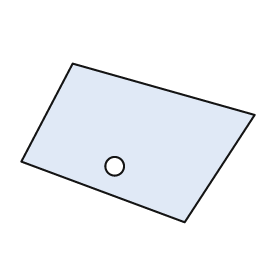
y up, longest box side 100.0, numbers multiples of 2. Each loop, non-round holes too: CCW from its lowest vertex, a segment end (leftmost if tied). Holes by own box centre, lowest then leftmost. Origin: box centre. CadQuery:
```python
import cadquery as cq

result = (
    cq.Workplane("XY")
    .moveTo(20.0, -34.0)
    .lineTo(50.0, 12.0)
    .lineTo(-28.0, 34.0)
    .lineTo(-50.0, -8.0)
    .close()
    .moveTo(-10.0, -10.0)
    .circle(4.0)
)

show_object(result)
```